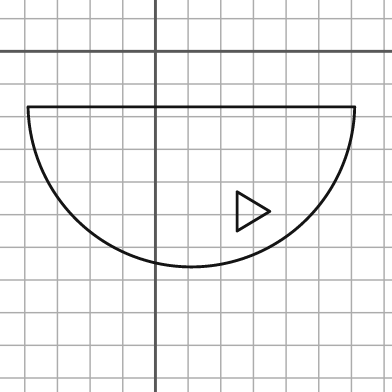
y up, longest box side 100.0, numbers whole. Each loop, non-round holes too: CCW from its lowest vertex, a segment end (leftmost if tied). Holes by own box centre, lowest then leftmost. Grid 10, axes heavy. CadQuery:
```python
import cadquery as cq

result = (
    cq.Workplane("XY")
    .moveTo(-39.0, -17.0)
    .threePointArc((11.0, -66.0), (61.0, -17.0))
    .close()
    .moveTo(25.0, -55.0)
    .lineTo(35.0, -49.0)
    .lineTo(25.0, -43.0)
    .close()
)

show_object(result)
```